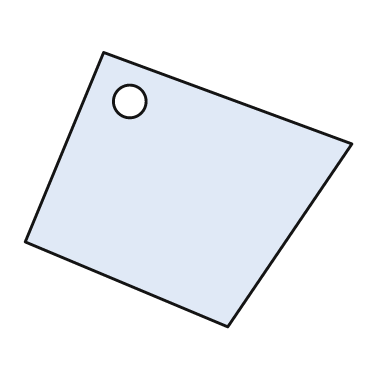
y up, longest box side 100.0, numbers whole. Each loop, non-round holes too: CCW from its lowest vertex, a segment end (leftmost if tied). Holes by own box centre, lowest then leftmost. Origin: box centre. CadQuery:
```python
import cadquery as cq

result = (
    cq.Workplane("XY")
    .moveTo(12.0, -42.0)
    .lineTo(50.0, 14.0)
    .lineTo(-26.0, 42.0)
    .lineTo(-50.0, -16.0)
    .close()
    .moveTo(-18.0, 27.0)
    .circle(5.0)
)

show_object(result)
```